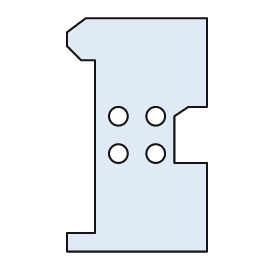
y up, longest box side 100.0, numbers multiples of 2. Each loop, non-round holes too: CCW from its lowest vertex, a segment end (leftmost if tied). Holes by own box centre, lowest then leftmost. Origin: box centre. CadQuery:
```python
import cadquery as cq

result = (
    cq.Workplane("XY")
    .moveTo(-30.0, -50.0)
    .lineTo(30.0, -50.0)
    .lineTo(30.0, -12.0)
    .lineTo(16.0, -12.0)
    .lineTo(16.0, 8.0)
    .lineTo(22.0, 12.0)
    .lineTo(30.0, 12.0)
    .lineTo(30.0, 50.0)
    .lineTo(-22.0, 50.0)
    .lineTo(-30.0, 44.0)
    .lineTo(-30.0, 38.0)
    .lineTo(-24.0, 32.0)
    .lineTo(-18.0, 32.0)
    .lineTo(-18.0, -42.0)
    .lineTo(-30.0, -42.0)
    .close()
    .moveTo(-8.0, -8.0)
    .circle(4.0)
    .moveTo(8.0, -8.0)
    .circle(4.0)
    .moveTo(-8.0, 8.0)
    .circle(4.0)
    .moveTo(8.0, 8.0)
    .circle(4.0)
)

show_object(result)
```